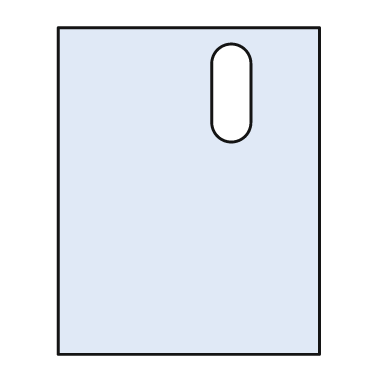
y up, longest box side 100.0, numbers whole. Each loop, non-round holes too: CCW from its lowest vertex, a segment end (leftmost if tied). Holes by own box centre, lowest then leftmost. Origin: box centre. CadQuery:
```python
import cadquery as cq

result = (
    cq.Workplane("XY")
    .moveTo(-40.0, -50.0)
    .lineTo(40.0, -50.0)
    .lineTo(40.0, 50.0)
    .lineTo(-40.0, 50.0)
    .close()
    .moveTo(7.0, 21.0)
    .threePointArc((13.0, 15.0), (19.0, 21.0))
    .lineTo(19.0, 39.0)
    .threePointArc((13.0, 45.0), (7.0, 39.0))
    .close()
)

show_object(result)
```